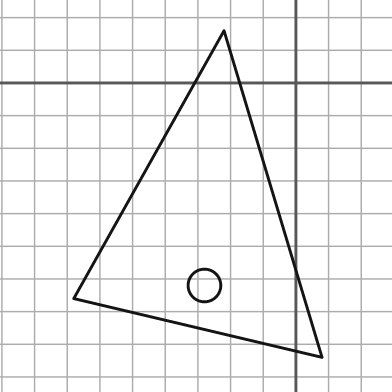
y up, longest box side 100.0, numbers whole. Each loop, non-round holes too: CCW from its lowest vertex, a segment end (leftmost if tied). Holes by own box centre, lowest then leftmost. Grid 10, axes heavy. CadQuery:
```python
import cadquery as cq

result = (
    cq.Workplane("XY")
    .moveTo(8.0, -84.0)
    .lineTo(-22.0, 16.0)
    .lineTo(-68.0, -66.0)
    .close()
    .moveTo(-28.0, -62.0)
    .circle(5.0)
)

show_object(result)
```